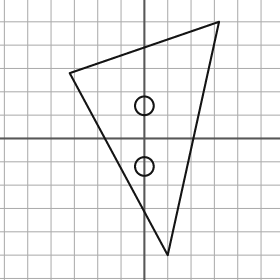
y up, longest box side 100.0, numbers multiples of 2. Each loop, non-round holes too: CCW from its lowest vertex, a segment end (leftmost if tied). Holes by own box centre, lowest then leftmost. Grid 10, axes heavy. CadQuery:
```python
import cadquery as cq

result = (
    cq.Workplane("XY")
    .moveTo(10.0, -50.0)
    .lineTo(32.0, 50.0)
    .lineTo(-32.0, 28.0)
    .close()
    .moveTo(0.0, -12.0)
    .circle(4.0)
    .moveTo(0.0, 14.0)
    .circle(4.0)
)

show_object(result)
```